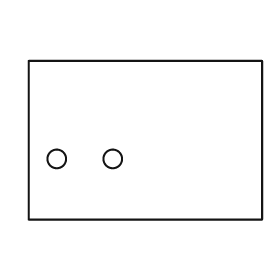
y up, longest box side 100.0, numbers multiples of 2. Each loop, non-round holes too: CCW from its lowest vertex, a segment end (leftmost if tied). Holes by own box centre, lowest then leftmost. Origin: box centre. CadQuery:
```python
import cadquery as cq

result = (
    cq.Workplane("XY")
    .moveTo(-50.0, -34.0)
    .lineTo(50.0, -34.0)
    .lineTo(50.0, 34.0)
    .lineTo(-50.0, 34.0)
    .close()
    .moveTo(-38.0, -8.0)
    .circle(4.0)
    .moveTo(-14.0, -8.0)
    .circle(4.0)
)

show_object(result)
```